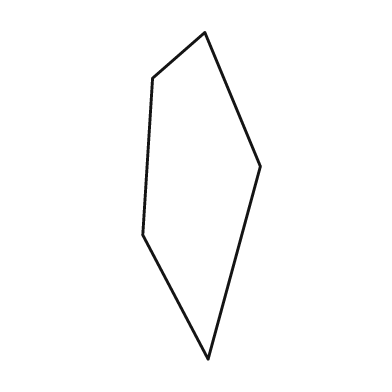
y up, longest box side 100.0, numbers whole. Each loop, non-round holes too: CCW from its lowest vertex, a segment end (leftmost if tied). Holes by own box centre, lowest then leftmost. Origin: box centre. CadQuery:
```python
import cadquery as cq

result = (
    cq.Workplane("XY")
    .moveTo(2.0, -50.0)
    .lineTo(18.0, 9.0)
    .lineTo(1.0, 50.0)
    .lineTo(-15.0, 36.0)
    .lineTo(-18.0, -12.0)
    .close()
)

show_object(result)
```